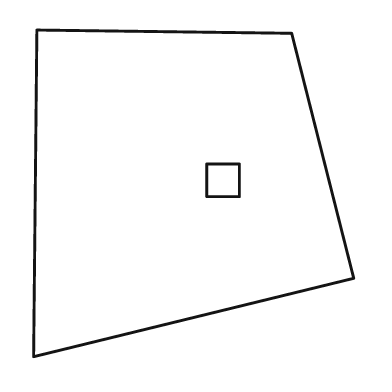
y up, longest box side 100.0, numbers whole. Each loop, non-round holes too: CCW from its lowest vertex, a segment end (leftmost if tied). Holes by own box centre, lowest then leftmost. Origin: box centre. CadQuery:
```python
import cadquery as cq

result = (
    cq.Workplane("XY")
    .moveTo(-49.0, -50.0)
    .lineTo(49.0, -26.0)
    .lineTo(30.0, 49.0)
    .lineTo(-48.0, 50.0)
    .close()
    .moveTo(4.0, -1.0)
    .lineTo(14.0, -1.0)
    .lineTo(14.0, 9.0)
    .lineTo(4.0, 9.0)
    .close()
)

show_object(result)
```